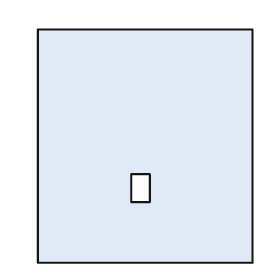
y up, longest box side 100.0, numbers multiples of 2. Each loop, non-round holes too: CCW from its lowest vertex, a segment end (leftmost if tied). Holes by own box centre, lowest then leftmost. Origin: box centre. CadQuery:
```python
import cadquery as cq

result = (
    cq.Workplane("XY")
    .moveTo(-46.0, -50.0)
    .lineTo(46.0, -50.0)
    .lineTo(46.0, 50.0)
    .lineTo(-46.0, 50.0)
    .close()
    .moveTo(-6.0, -24.0)
    .lineTo(2.0, -24.0)
    .lineTo(2.0, -12.0)
    .lineTo(-6.0, -12.0)
    .close()
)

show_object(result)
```